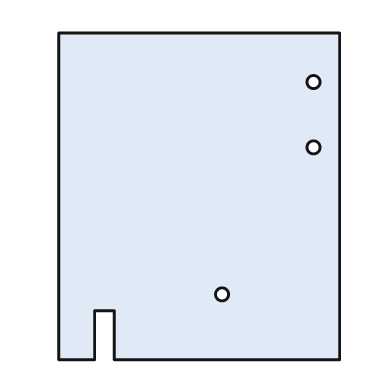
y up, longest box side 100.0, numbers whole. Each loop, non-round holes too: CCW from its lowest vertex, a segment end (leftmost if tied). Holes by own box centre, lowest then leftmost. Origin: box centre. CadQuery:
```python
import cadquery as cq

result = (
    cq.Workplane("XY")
    .moveTo(-43.0, -50.0)
    .lineTo(-32.0, -50.0)
    .lineTo(-32.0, -35.0)
    .lineTo(-26.0, -35.0)
    .lineTo(-26.0, -50.0)
    .lineTo(43.0, -50.0)
    .lineTo(43.0, 50.0)
    .lineTo(-43.0, 50.0)
    .close()
    .moveTo(7.0, -30.0)
    .circle(2.0)
    .moveTo(35.0, 15.0)
    .circle(2.0)
    .moveTo(35.0, 35.0)
    .circle(2.0)
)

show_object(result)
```